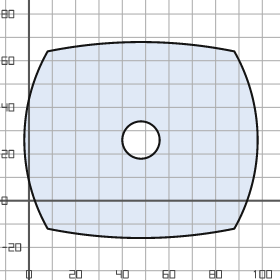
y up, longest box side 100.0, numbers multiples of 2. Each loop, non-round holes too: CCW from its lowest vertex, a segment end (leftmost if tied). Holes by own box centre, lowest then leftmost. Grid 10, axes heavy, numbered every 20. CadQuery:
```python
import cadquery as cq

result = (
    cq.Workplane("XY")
    .moveTo(8.0, -12.0)
    .threePointArc((48.0, -16.0), (88.0, -12.0))
    .threePointArc((98.0, 26.0), (88.0, 64.0))
    .threePointArc((48.0, 68.0), (8.0, 64.0))
    .threePointArc((-2.0, 26.0), (8.0, -12.0))
    .close()
    .moveTo(48.0, 26.0)
    .circle(8.0)
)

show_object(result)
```